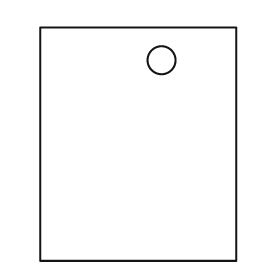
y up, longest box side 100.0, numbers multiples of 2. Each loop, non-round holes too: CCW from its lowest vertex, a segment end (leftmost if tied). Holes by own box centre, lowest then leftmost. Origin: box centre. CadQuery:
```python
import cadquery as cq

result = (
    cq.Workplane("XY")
    .moveTo(-42.0, -50.0)
    .lineTo(42.0, -50.0)
    .lineTo(42.0, 50.0)
    .lineTo(-42.0, 50.0)
    .close()
    .moveTo(10.0, 36.0)
    .circle(6.0)
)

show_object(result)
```